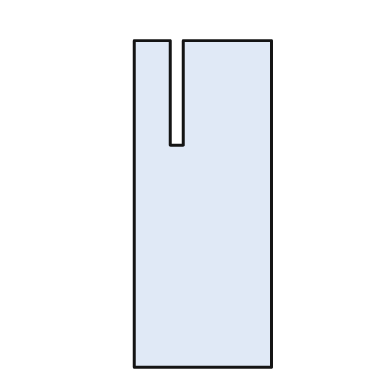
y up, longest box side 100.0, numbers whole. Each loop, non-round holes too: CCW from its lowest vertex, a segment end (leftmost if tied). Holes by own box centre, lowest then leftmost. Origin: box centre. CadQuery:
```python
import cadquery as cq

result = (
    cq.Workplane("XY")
    .moveTo(-21.0, -50.0)
    .lineTo(21.0, -50.0)
    .lineTo(21.0, 50.0)
    .lineTo(-6.0, 50.0)
    .lineTo(-6.0, 18.0)
    .lineTo(-10.0, 18.0)
    .lineTo(-10.0, 50.0)
    .lineTo(-21.0, 50.0)
    .close()
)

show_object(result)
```